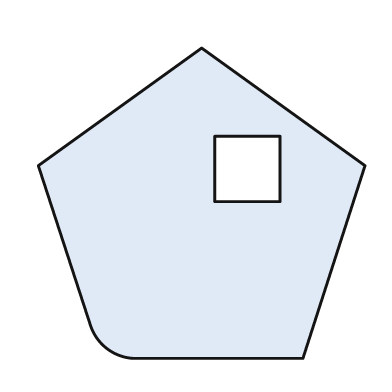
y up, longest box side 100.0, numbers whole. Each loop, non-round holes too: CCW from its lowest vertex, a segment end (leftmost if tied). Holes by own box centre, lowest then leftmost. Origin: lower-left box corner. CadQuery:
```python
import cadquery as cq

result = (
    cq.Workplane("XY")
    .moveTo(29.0, 0.0)
    .lineTo(81.0, 0.0)
    .lineTo(100.0, 59.0)
    .lineTo(50.0, 95.0)
    .lineTo(0.0, 59.0)
    .lineTo(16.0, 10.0)
    .threePointArc((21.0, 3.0), (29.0, 0.0))
    .close()
    .moveTo(54.0, 48.0)
    .lineTo(74.0, 48.0)
    .lineTo(74.0, 68.0)
    .lineTo(54.0, 68.0)
    .close()
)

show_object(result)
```